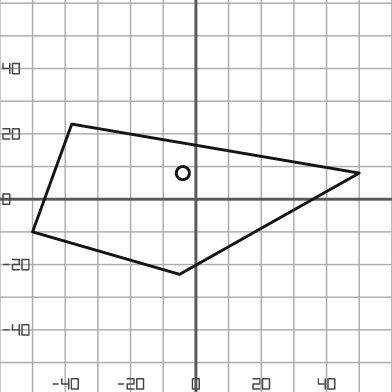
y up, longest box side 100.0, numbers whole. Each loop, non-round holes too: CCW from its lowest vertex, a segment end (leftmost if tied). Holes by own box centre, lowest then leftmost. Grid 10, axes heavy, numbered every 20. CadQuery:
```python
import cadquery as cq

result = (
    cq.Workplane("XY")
    .moveTo(-5.0, -23.0)
    .lineTo(50.0, 8.0)
    .lineTo(-38.0, 23.0)
    .lineTo(-50.0, -10.0)
    .close()
    .moveTo(-4.0, 8.0)
    .circle(2.0)
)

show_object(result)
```